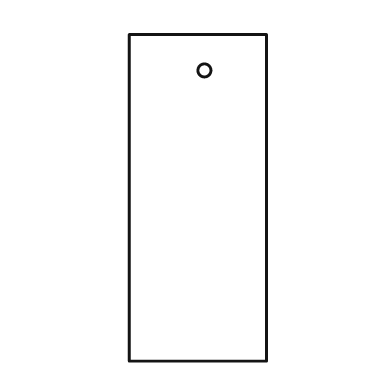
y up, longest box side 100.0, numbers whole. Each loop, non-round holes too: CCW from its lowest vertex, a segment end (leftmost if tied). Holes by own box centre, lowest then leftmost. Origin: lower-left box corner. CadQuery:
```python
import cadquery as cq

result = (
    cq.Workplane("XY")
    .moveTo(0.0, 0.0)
    .lineTo(42.0, 0.0)
    .lineTo(42.0, 100.0)
    .lineTo(0.0, 100.0)
    .close()
    .moveTo(23.0, 89.0)
    .circle(2.0)
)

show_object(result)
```